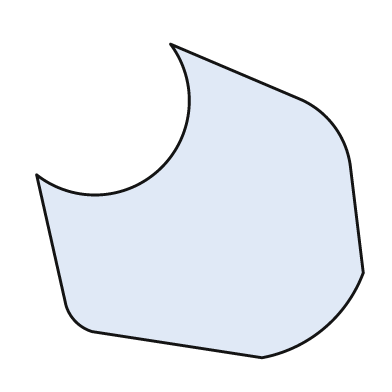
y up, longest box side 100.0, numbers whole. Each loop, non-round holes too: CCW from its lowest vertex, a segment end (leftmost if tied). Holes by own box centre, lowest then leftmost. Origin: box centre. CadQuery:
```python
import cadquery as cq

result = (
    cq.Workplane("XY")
    .moveTo(19.0, -48.0)
    .threePointArc((38.0, -39.0), (50.0, -22.0))
    .lineTo(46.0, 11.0)
    .threePointArc((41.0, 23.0), (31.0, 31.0))
    .lineTo(-9.0, 48.0)
    .threePointArc((-12.0, 10.0), (-50.0, 8.0))
    .lineTo(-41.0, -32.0)
    .threePointArc((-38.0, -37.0), (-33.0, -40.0))
    .close()
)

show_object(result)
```